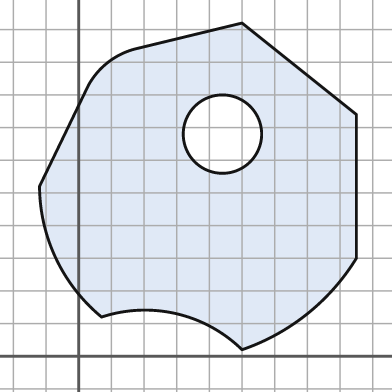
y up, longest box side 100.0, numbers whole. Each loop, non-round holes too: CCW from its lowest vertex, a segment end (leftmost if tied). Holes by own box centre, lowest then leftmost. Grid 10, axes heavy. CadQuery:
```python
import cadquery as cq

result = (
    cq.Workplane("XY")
    .moveTo(50.0, 2.0)
    .threePointArc((70.0, 13.0), (85.0, 30.0))
    .lineTo(85.0, 74.0)
    .lineTo(50.0, 102.0)
    .lineTo(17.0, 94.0)
    .threePointArc((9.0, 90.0), (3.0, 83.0))
    .lineTo(-12.0, 52.0)
    .threePointArc((-7.0, 30.0), (7.0, 12.0))
    .threePointArc((30.0, 13.0), (50.0, 2.0))
    .close()
    .moveTo(44.0, 68.0)
    .circle(12.0)
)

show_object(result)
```